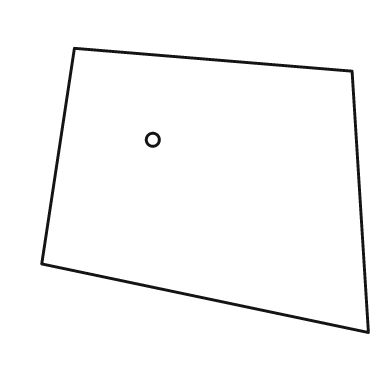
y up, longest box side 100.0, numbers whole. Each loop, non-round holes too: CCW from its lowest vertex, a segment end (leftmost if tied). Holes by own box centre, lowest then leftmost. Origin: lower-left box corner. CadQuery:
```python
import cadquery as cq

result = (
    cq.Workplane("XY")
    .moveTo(100.0, 0.0)
    .lineTo(95.0, 80.0)
    .lineTo(10.0, 87.0)
    .lineTo(0.0, 21.0)
    .close()
    .moveTo(34.0, 59.0)
    .circle(2.0)
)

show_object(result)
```